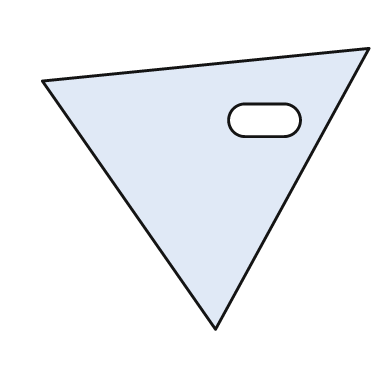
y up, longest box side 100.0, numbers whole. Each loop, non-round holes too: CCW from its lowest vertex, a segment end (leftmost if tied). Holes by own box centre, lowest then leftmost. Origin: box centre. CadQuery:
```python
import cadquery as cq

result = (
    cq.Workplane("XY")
    .moveTo(3.0, -43.0)
    .lineTo(50.0, 43.0)
    .lineTo(-50.0, 33.0)
    .close()
    .moveTo(12.0, 16.0)
    .lineTo(24.0, 16.0)
    .threePointArc((29.0, 21.0), (24.0, 26.0))
    .lineTo(12.0, 26.0)
    .threePointArc((7.0, 21.0), (12.0, 16.0))
    .close()
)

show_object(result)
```